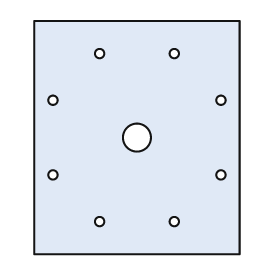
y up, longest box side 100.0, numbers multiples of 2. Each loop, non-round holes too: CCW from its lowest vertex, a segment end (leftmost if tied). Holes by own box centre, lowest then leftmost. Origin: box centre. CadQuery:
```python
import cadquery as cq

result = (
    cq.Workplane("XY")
    .moveTo(-44.0, -50.0)
    .lineTo(44.0, -50.0)
    .lineTo(44.0, 50.0)
    .lineTo(-44.0, 50.0)
    .close()
    .moveTo(-16.0, -36.0)
    .circle(2.0)
    .moveTo(16.0, -36.0)
    .circle(2.0)
    .moveTo(-36.0, -16.0)
    .circle(2.0)
    .moveTo(36.0, -16.0)
    .circle(2.0)
    .moveTo(0.0, 0.0)
    .circle(6.0)
    .moveTo(-36.0, 16.0)
    .circle(2.0)
    .moveTo(36.0, 16.0)
    .circle(2.0)
    .moveTo(-16.0, 36.0)
    .circle(2.0)
    .moveTo(16.0, 36.0)
    .circle(2.0)
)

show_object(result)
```